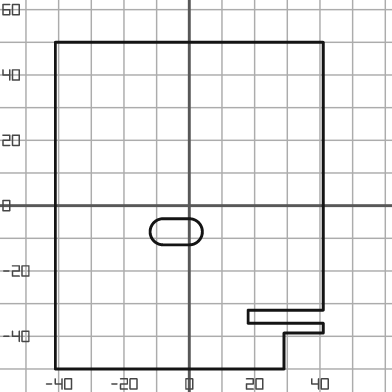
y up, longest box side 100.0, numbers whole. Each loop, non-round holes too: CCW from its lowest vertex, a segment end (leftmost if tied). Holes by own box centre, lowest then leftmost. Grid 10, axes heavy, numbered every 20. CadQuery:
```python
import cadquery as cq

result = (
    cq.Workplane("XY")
    .moveTo(-41.0, -50.0)
    .lineTo(29.0, -50.0)
    .lineTo(29.0, -39.0)
    .lineTo(41.0, -39.0)
    .lineTo(41.0, -36.0)
    .lineTo(18.0, -36.0)
    .lineTo(18.0, -32.0)
    .lineTo(41.0, -32.0)
    .lineTo(41.0, 50.0)
    .lineTo(-41.0, 50.0)
    .close()
    .moveTo(-8.0, -12.0)
    .lineTo(0.0, -12.0)
    .threePointArc((4.0, -8.0), (0.0, -4.0))
    .lineTo(-8.0, -4.0)
    .threePointArc((-12.0, -8.0), (-8.0, -12.0))
    .close()
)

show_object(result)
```